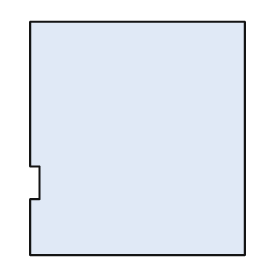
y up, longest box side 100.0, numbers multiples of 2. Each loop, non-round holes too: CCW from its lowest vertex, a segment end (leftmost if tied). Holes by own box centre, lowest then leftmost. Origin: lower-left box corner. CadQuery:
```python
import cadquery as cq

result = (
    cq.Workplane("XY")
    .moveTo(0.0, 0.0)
    .lineTo(92.0, 0.0)
    .lineTo(92.0, 100.0)
    .lineTo(0.0, 100.0)
    .lineTo(0.0, 38.0)
    .lineTo(4.0, 38.0)
    .lineTo(4.0, 24.0)
    .lineTo(0.0, 24.0)
    .close()
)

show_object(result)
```